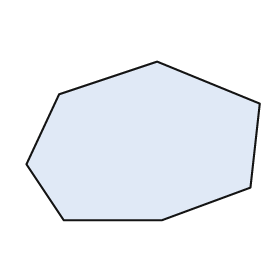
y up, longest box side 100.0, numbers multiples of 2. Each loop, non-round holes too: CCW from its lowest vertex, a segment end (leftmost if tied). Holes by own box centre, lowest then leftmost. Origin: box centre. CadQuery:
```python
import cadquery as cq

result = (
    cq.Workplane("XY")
    .moveTo(-34.0, -34.0)
    .lineTo(8.0, -34.0)
    .lineTo(46.0, -20.0)
    .lineTo(50.0, 16.0)
    .lineTo(6.0, 34.0)
    .lineTo(-36.0, 20.0)
    .lineTo(-50.0, -10.0)
    .close()
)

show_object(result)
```